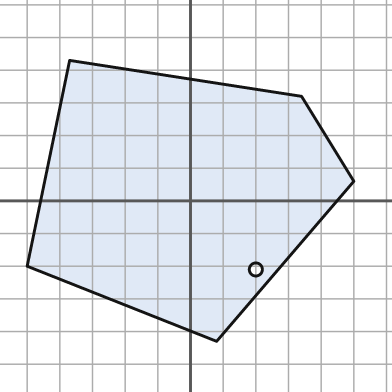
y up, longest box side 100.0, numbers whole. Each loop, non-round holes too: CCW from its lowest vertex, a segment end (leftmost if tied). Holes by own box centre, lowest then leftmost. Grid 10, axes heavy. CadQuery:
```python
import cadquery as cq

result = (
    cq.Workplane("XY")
    .moveTo(8.0, -43.0)
    .lineTo(50.0, 6.0)
    .lineTo(34.0, 32.0)
    .lineTo(-37.0, 43.0)
    .lineTo(-50.0, -20.0)
    .close()
    .moveTo(20.0, -21.0)
    .circle(2.0)
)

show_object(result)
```